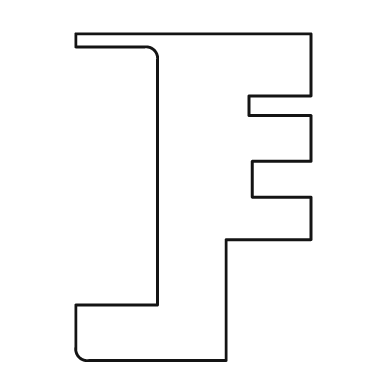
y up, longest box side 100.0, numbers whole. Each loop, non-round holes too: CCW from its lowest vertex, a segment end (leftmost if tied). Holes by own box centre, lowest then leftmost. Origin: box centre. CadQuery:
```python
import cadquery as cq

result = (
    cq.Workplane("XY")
    .moveTo(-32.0, -50.0)
    .lineTo(10.0, -50.0)
    .lineTo(10.0, -13.0)
    .lineTo(36.0, -13.0)
    .lineTo(36.0, 0.0)
    .lineTo(18.0, 0.0)
    .lineTo(18.0, 11.0)
    .lineTo(36.0, 11.0)
    .lineTo(36.0, 25.0)
    .lineTo(17.0, 25.0)
    .lineTo(17.0, 31.0)
    .lineTo(36.0, 31.0)
    .lineTo(36.0, 50.0)
    .lineTo(-36.0, 50.0)
    .lineTo(-36.0, 46.0)
    .lineTo(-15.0, 46.0)
    .threePointArc((-12.0, 45.0), (-11.0, 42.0))
    .lineTo(-11.0, -33.0)
    .lineTo(-36.0, -33.0)
    .lineTo(-36.0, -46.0)
    .threePointArc((-35.0, -49.0), (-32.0, -50.0))
    .close()
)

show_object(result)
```